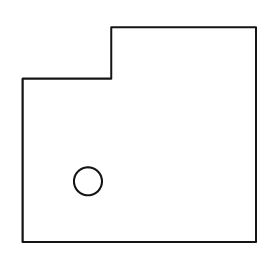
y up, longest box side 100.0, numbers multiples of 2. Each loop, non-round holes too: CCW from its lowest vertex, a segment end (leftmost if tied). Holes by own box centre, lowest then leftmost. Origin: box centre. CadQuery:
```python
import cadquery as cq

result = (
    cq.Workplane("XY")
    .moveTo(-50.0, -46.0)
    .lineTo(50.0, -46.0)
    .lineTo(50.0, 46.0)
    .lineTo(-12.0, 46.0)
    .lineTo(-12.0, 24.0)
    .lineTo(-50.0, 24.0)
    .close()
    .moveTo(-22.0, -20.0)
    .circle(6.0)
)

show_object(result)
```